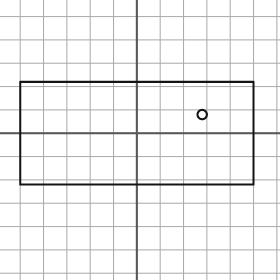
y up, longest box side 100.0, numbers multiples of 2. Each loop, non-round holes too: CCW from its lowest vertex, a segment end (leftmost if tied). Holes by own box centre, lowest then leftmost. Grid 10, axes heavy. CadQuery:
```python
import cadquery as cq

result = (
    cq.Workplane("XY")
    .moveTo(-50.0, -22.0)
    .lineTo(50.0, -22.0)
    .lineTo(50.0, 22.0)
    .lineTo(-50.0, 22.0)
    .close()
    .moveTo(28.0, 8.0)
    .circle(2.0)
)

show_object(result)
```